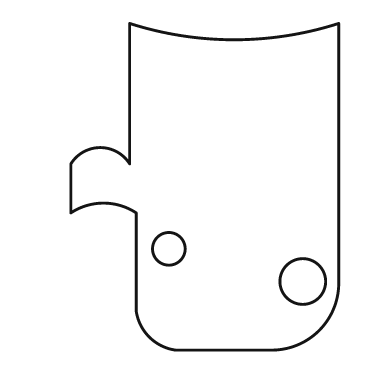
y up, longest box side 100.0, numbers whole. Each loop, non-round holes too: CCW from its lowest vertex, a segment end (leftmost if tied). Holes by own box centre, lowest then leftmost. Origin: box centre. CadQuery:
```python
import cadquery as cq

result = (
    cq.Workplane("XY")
    .moveTo(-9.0, -50.0)
    .lineTo(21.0, -50.0)
    .threePointArc((35.0, -44.0), (41.0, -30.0))
    .lineTo(41.0, 50.0)
    .threePointArc((9.0, 45.0), (-23.0, 50.0))
    .lineTo(-23.0, 7.0)
    .threePointArc((-32.0, 12.0), (-41.0, 7.0))
    .lineTo(-41.0, -8.0)
    .threePointArc((-31.0, -5.0), (-21.0, -8.0))
    .lineTo(-21.0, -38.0)
    .threePointArc((-17.0, -46.0), (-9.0, -50.0))
    .close()
    .moveTo(30.0, -29.0)
    .circle(7.0)
    .moveTo(-11.0, -19.0)
    .circle(5.0)
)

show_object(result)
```